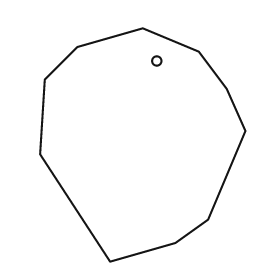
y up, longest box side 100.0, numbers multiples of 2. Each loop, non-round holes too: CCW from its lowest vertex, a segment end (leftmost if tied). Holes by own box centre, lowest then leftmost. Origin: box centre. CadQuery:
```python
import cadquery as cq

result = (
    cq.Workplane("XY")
    .moveTo(-14.0, -50.0)
    .lineTo(14.0, -42.0)
    .lineTo(28.0, -32.0)
    .lineTo(44.0, 6.0)
    .lineTo(36.0, 24.0)
    .lineTo(24.0, 40.0)
    .lineTo(0.0, 50.0)
    .lineTo(-28.0, 42.0)
    .lineTo(-42.0, 28.0)
    .lineTo(-44.0, -4.0)
    .close()
    .moveTo(6.0, 36.0)
    .circle(2.0)
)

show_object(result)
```